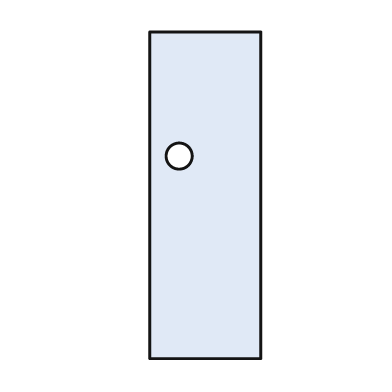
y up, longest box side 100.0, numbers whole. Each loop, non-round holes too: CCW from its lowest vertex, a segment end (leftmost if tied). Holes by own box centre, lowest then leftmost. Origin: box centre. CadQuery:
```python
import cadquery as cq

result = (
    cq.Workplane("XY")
    .moveTo(-17.0, -50.0)
    .lineTo(17.0, -50.0)
    .lineTo(17.0, 50.0)
    .lineTo(-17.0, 50.0)
    .close()
    .moveTo(-8.0, 12.0)
    .circle(4.0)
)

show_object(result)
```